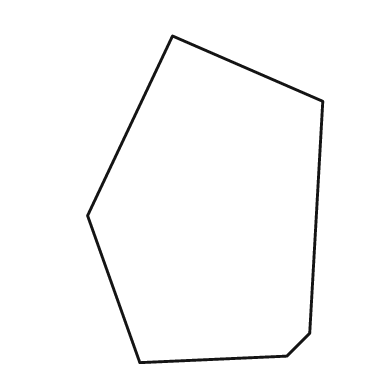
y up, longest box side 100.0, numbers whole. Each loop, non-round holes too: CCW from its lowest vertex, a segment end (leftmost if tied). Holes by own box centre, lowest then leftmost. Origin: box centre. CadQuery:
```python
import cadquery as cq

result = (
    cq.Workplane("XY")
    .moveTo(-20.0, -50.0)
    .lineTo(25.0, -48.0)
    .lineTo(32.0, -41.0)
    .lineTo(36.0, 30.0)
    .lineTo(-10.0, 50.0)
    .lineTo(-36.0, -5.0)
    .close()
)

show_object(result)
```